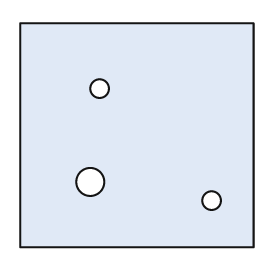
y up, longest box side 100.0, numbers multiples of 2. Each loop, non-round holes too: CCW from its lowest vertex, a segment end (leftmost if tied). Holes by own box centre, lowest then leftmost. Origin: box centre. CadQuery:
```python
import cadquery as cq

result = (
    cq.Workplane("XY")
    .moveTo(-50.0, -48.0)
    .lineTo(50.0, -48.0)
    .lineTo(50.0, 48.0)
    .lineTo(-50.0, 48.0)
    .close()
    .moveTo(32.0, -28.0)
    .circle(4.0)
    .moveTo(-20.0, -20.0)
    .circle(6.0)
    .moveTo(-16.0, 20.0)
    .circle(4.0)
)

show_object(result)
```